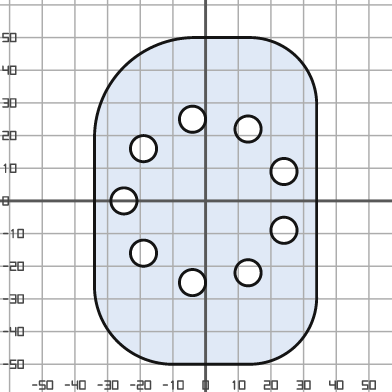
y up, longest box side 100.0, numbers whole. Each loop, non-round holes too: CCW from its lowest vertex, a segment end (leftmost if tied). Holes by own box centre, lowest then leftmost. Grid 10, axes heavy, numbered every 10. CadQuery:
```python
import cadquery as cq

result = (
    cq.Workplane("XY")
    .moveTo(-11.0, -50.0)
    .lineTo(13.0, -50.0)
    .threePointArc((28.0, -44.0), (34.0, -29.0))
    .lineTo(34.0, 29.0)
    .threePointArc((28.0, 44.0), (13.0, 50.0))
    .lineTo(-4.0, 50.0)
    .threePointArc((-25.0, 41.0), (-34.0, 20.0))
    .lineTo(-34.0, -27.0)
    .threePointArc((-27.0, -43.0), (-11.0, -50.0))
    .close()
    .moveTo(-4.0, -25.0)
    .circle(4.0)
    .moveTo(13.0, -22.0)
    .circle(4.0)
    .moveTo(-19.0, -16.0)
    .circle(4.0)
    .moveTo(24.0, -9.0)
    .circle(4.0)
    .moveTo(-25.0, 0.0)
    .circle(4.0)
    .moveTo(24.0, 9.0)
    .circle(4.0)
    .moveTo(-19.0, 16.0)
    .circle(4.0)
    .moveTo(13.0, 22.0)
    .circle(4.0)
    .moveTo(-4.0, 25.0)
    .circle(4.0)
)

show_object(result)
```